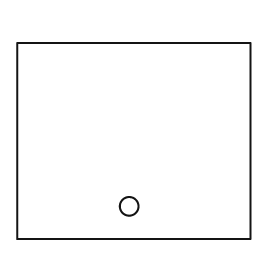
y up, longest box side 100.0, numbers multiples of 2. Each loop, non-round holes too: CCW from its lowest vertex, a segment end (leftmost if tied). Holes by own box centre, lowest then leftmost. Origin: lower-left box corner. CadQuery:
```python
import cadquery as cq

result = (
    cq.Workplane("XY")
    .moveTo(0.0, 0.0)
    .lineTo(100.0, 0.0)
    .lineTo(100.0, 84.0)
    .lineTo(0.0, 84.0)
    .close()
    .moveTo(48.0, 14.0)
    .circle(4.0)
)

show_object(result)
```